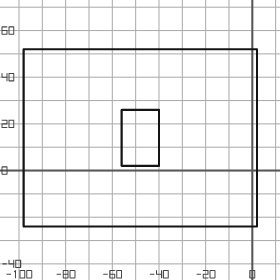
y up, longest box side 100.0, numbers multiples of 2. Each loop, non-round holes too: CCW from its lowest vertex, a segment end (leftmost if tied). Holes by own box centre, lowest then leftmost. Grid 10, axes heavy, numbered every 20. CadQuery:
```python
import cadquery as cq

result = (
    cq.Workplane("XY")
    .moveTo(-98.0, -24.0)
    .lineTo(2.0, -24.0)
    .lineTo(2.0, 52.0)
    .lineTo(-98.0, 52.0)
    .close()
    .moveTo(-56.0, 2.0)
    .lineTo(-40.0, 2.0)
    .lineTo(-40.0, 26.0)
    .lineTo(-56.0, 26.0)
    .close()
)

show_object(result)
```